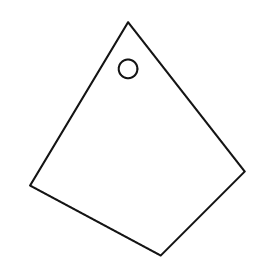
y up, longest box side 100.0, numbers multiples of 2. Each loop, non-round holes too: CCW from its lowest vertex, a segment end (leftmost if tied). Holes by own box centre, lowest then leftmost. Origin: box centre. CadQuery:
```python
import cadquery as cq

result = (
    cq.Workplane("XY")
    .moveTo(10.0, -50.0)
    .lineTo(46.0, -14.0)
    .lineTo(-4.0, 50.0)
    .lineTo(-46.0, -20.0)
    .close()
    .moveTo(-4.0, 30.0)
    .circle(4.0)
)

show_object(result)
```